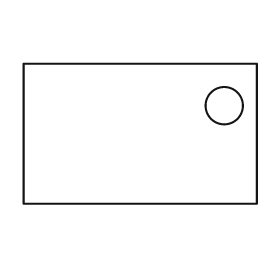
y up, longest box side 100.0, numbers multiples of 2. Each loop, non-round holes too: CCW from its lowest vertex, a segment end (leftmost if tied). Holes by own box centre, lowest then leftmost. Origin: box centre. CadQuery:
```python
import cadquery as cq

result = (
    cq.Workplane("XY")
    .moveTo(-50.0, -30.0)
    .lineTo(50.0, -30.0)
    .lineTo(50.0, 30.0)
    .lineTo(-50.0, 30.0)
    .close()
    .moveTo(36.0, 12.0)
    .circle(8.0)
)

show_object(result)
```